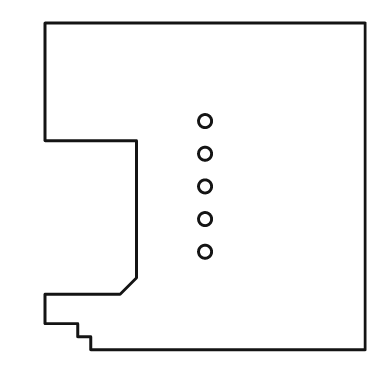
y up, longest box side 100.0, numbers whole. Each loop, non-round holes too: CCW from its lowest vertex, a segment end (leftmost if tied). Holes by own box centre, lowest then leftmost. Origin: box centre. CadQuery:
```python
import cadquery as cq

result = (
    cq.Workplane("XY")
    .moveTo(-35.0, -50.0)
    .lineTo(49.0, -50.0)
    .lineTo(49.0, 50.0)
    .lineTo(-49.0, 50.0)
    .lineTo(-49.0, 14.0)
    .lineTo(-21.0, 14.0)
    .lineTo(-21.0, -28.0)
    .lineTo(-26.0, -33.0)
    .lineTo(-49.0, -33.0)
    .lineTo(-49.0, -42.0)
    .lineTo(-39.0, -42.0)
    .lineTo(-39.0, -46.0)
    .lineTo(-35.0, -46.0)
    .close()
    .moveTo(0.0, -20.0)
    .circle(2.0)
    .moveTo(0.0, -10.0)
    .circle(2.0)
    .moveTo(0.0, 0.0)
    .circle(2.0)
    .moveTo(0.0, 10.0)
    .circle(2.0)
    .moveTo(0.0, 20.0)
    .circle(2.0)
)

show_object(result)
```